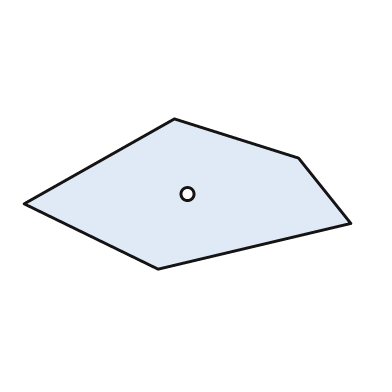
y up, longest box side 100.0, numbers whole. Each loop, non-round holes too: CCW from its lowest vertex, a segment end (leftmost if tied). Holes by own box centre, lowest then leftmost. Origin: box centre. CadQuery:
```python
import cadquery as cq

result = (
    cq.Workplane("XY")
    .moveTo(-9.0, -23.0)
    .lineTo(50.0, -9.0)
    .lineTo(34.0, 11.0)
    .lineTo(-4.0, 23.0)
    .lineTo(-50.0, -3.0)
    .close()
    .moveTo(0.0, 0.0)
    .circle(2.0)
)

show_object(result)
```